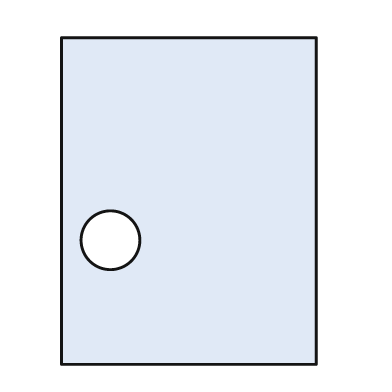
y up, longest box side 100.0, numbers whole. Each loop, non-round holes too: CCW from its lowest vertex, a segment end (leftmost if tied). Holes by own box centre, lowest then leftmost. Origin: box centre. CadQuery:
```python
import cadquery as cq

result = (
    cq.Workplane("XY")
    .moveTo(-39.0, -50.0)
    .lineTo(39.0, -50.0)
    .lineTo(39.0, 50.0)
    .lineTo(-39.0, 50.0)
    .close()
    .moveTo(-24.0, -12.0)
    .circle(9.0)
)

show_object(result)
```